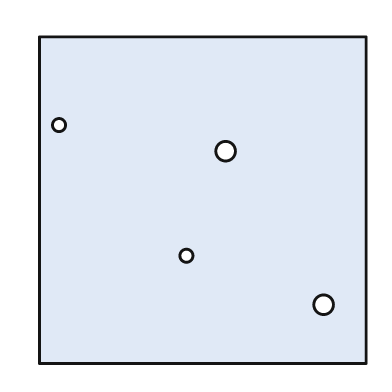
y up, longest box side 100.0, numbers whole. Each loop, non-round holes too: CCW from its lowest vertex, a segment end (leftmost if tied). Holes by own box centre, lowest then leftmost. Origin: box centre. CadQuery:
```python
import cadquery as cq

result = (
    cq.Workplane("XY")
    .moveTo(-50.0, -50.0)
    .lineTo(50.0, -50.0)
    .lineTo(50.0, 50.0)
    .lineTo(-50.0, 50.0)
    .close()
    .moveTo(37.0, -32.0)
    .circle(3.0)
    .moveTo(-5.0, -17.0)
    .circle(2.0)
    .moveTo(7.0, 15.0)
    .circle(3.0)
    .moveTo(-44.0, 23.0)
    .circle(2.0)
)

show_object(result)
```